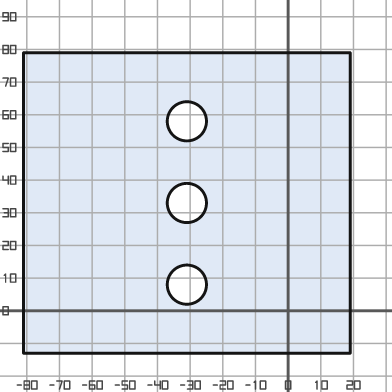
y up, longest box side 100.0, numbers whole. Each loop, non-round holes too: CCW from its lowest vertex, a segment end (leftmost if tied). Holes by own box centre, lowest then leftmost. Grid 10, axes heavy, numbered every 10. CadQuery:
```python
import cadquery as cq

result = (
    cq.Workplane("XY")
    .moveTo(-81.0, -13.0)
    .lineTo(19.0, -13.0)
    .lineTo(19.0, 79.0)
    .lineTo(-81.0, 79.0)
    .close()
    .moveTo(-31.0, 8.0)
    .circle(6.0)
    .moveTo(-31.0, 33.0)
    .circle(6.0)
    .moveTo(-31.0, 58.0)
    .circle(6.0)
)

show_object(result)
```